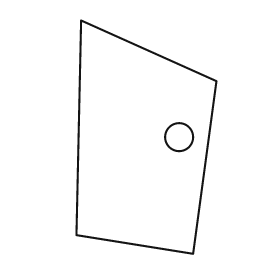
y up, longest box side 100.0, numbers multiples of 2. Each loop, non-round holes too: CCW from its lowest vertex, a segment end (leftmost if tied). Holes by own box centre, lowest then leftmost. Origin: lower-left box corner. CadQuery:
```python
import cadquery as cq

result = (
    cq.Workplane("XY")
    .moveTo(50.0, 0.0)
    .lineTo(60.0, 74.0)
    .lineTo(2.0, 100.0)
    .lineTo(0.0, 8.0)
    .close()
    .moveTo(44.0, 50.0)
    .circle(6.0)
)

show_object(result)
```